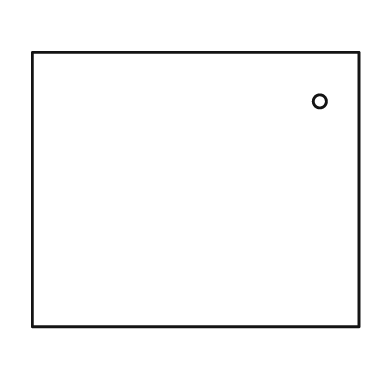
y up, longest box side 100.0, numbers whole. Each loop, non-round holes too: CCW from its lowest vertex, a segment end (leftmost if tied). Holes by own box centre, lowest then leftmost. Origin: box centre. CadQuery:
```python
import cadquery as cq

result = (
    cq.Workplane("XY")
    .moveTo(-50.0, -42.0)
    .lineTo(50.0, -42.0)
    .lineTo(50.0, 42.0)
    .lineTo(-50.0, 42.0)
    .close()
    .moveTo(38.0, 27.0)
    .circle(2.0)
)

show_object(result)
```